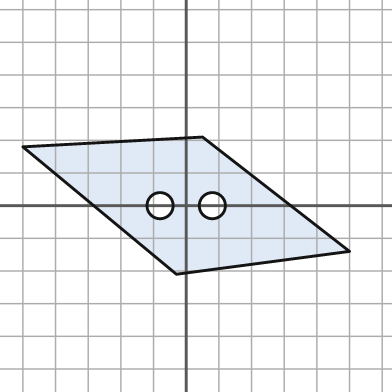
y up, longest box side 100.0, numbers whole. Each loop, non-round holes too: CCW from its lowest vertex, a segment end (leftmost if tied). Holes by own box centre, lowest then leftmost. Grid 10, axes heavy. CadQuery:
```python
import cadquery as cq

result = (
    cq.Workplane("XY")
    .moveTo(-3.0, -21.0)
    .lineTo(50.0, -14.0)
    .lineTo(5.0, 21.0)
    .lineTo(-50.0, 18.0)
    .close()
    .moveTo(-8.0, 0.0)
    .circle(4.0)
    .moveTo(8.0, 0.0)
    .circle(4.0)
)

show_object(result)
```